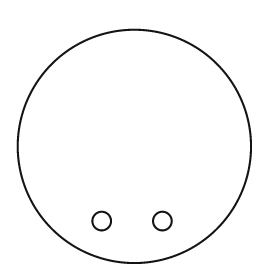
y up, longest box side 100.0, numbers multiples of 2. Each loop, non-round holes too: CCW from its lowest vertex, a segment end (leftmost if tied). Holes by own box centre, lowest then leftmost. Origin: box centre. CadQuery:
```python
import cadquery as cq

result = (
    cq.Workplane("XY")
    .moveTo(0.0, 0.0)
    .circle(50.0)
    .moveTo(-14.0, -32.0)
    .circle(4.0)
    .moveTo(12.0, -32.0)
    .circle(4.0)
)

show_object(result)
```